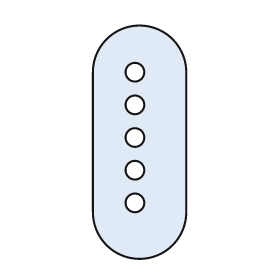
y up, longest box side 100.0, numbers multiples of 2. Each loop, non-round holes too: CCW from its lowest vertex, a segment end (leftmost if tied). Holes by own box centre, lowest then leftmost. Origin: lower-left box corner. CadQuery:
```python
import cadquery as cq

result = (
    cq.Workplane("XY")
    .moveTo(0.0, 20.0)
    .threePointArc((20.0, 0.0), (40.0, 20.0))
    .lineTo(40.0, 80.0)
    .threePointArc((20.0, 100.0), (0.0, 80.0))
    .close()
    .moveTo(18.0, 24.0)
    .circle(4.0)
    .moveTo(18.0, 38.0)
    .circle(4.0)
    .moveTo(18.0, 52.0)
    .circle(4.0)
    .moveTo(18.0, 66.0)
    .circle(4.0)
    .moveTo(18.0, 80.0)
    .circle(4.0)
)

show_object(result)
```